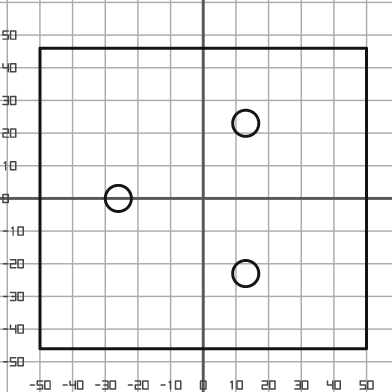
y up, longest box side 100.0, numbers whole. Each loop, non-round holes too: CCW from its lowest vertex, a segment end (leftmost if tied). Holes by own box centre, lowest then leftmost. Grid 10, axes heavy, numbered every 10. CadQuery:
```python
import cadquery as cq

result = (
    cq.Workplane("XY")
    .moveTo(-50.0, -46.0)
    .lineTo(50.0, -46.0)
    .lineTo(50.0, 46.0)
    .lineTo(-50.0, 46.0)
    .close()
    .moveTo(13.0, -23.0)
    .circle(4.0)
    .moveTo(-26.0, 0.0)
    .circle(4.0)
    .moveTo(13.0, 23.0)
    .circle(4.0)
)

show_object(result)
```